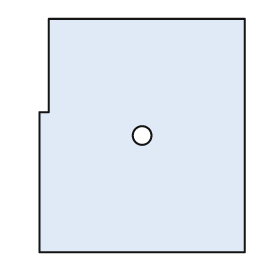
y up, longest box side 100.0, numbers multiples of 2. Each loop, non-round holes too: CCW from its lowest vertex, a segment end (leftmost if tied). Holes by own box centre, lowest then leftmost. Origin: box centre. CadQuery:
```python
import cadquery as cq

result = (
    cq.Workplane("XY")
    .moveTo(-44.0, -50.0)
    .lineTo(44.0, -50.0)
    .lineTo(44.0, 50.0)
    .lineTo(-40.0, 50.0)
    .lineTo(-40.0, 10.0)
    .lineTo(-44.0, 10.0)
    .close()
    .moveTo(0.0, 0.0)
    .circle(4.0)
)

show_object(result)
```